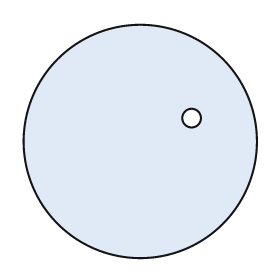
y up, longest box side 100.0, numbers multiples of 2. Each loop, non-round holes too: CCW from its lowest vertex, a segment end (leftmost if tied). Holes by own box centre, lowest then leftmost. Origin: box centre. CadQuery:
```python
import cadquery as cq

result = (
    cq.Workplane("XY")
    .moveTo(0.0, 0.0)
    .circle(50.0)
    .moveTo(22.0, 10.0)
    .circle(4.0)
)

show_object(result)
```